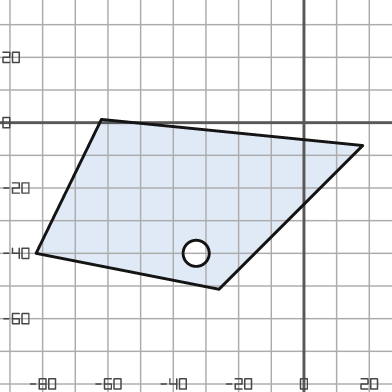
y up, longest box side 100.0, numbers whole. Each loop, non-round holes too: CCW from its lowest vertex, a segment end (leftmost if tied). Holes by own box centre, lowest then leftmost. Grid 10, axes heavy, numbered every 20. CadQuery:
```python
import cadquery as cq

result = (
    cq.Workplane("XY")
    .moveTo(-26.0, -51.0)
    .lineTo(18.0, -7.0)
    .lineTo(-62.0, 1.0)
    .lineTo(-82.0, -40.0)
    .close()
    .moveTo(-33.0, -40.0)
    .circle(4.0)
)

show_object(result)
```